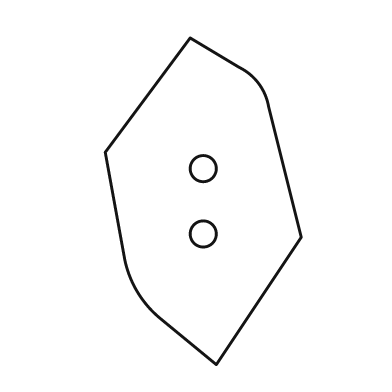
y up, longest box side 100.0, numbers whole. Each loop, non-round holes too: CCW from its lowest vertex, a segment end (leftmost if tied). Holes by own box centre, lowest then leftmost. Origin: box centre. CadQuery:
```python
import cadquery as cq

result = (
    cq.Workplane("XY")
    .moveTo(4.0, -50.0)
    .lineTo(30.0, -11.0)
    .lineTo(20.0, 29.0)
    .threePointArc((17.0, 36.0), (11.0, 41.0))
    .lineTo(-4.0, 50.0)
    .lineTo(-30.0, 15.0)
    .lineTo(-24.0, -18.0)
    .threePointArc((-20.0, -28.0), (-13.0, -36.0))
    .close()
    .moveTo(0.0, -10.0)
    .circle(4.0)
    .moveTo(0.0, 10.0)
    .circle(4.0)
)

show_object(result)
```